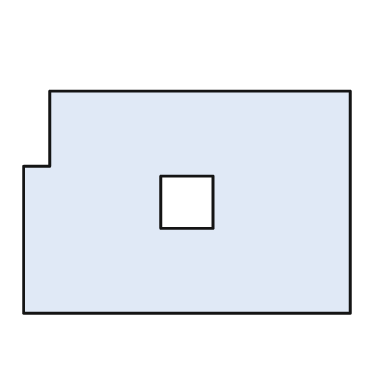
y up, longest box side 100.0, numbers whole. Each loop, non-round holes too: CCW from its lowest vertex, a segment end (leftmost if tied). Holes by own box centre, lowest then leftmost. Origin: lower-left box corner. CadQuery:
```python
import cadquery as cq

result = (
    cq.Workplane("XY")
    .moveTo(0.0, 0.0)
    .lineTo(100.0, 0.0)
    .lineTo(100.0, 68.0)
    .lineTo(8.0, 68.0)
    .lineTo(8.0, 45.0)
    .lineTo(0.0, 45.0)
    .close()
    .moveTo(42.0, 26.0)
    .lineTo(58.0, 26.0)
    .lineTo(58.0, 42.0)
    .lineTo(42.0, 42.0)
    .close()
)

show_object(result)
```